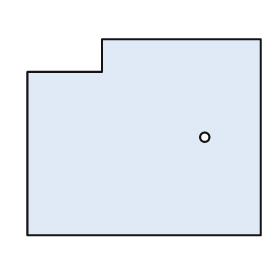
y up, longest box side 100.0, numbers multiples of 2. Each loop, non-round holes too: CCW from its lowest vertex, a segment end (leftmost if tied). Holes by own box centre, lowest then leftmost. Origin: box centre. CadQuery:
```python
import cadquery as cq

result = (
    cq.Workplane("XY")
    .moveTo(-50.0, -42.0)
    .lineTo(50.0, -42.0)
    .lineTo(50.0, 42.0)
    .lineTo(-18.0, 42.0)
    .lineTo(-18.0, 28.0)
    .lineTo(-50.0, 28.0)
    .close()
    .moveTo(26.0, 0.0)
    .circle(2.0)
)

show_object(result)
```